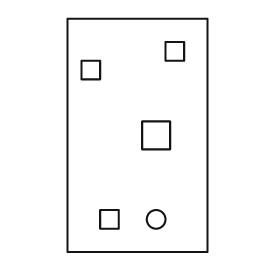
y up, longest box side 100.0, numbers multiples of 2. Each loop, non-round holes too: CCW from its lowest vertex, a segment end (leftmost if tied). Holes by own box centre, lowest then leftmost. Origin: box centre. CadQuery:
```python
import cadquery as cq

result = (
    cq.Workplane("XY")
    .moveTo(-30.0, -50.0)
    .lineTo(30.0, -50.0)
    .lineTo(30.0, 50.0)
    .lineTo(-30.0, 50.0)
    .close()
    .moveTo(-16.0, -40.0)
    .lineTo(-8.0, -40.0)
    .lineTo(-8.0, -32.0)
    .lineTo(-16.0, -32.0)
    .close()
    .moveTo(8.0, -36.0)
    .circle(4.0)
    .moveTo(2.0, -6.0)
    .lineTo(14.0, -6.0)
    .lineTo(14.0, 6.0)
    .lineTo(2.0, 6.0)
    .close()
    .moveTo(-24.0, 24.0)
    .lineTo(-16.0, 24.0)
    .lineTo(-16.0, 32.0)
    .lineTo(-24.0, 32.0)
    .close()
    .moveTo(12.0, 32.0)
    .lineTo(20.0, 32.0)
    .lineTo(20.0, 40.0)
    .lineTo(12.0, 40.0)
    .close()
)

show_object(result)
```